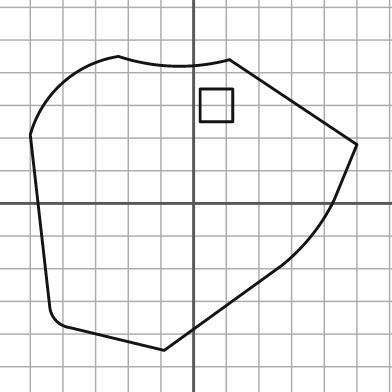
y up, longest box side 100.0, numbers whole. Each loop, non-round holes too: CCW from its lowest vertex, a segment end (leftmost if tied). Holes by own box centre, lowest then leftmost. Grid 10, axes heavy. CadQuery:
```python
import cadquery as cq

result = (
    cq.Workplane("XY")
    .moveTo(-9.0, -45.0)
    .lineTo(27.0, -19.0)
    .threePointArc((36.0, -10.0), (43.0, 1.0))
    .lineTo(50.0, 18.0)
    .lineTo(11.0, 44.0)
    .threePointArc((-6.0, 42.0), (-23.0, 45.0))
    .threePointArc((-40.0, 37.0), (-50.0, 21.0))
    .lineTo(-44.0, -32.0)
    .threePointArc((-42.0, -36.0), (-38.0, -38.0))
    .close()
    .moveTo(2.0, 25.0)
    .lineTo(12.0, 25.0)
    .lineTo(12.0, 35.0)
    .lineTo(2.0, 35.0)
    .close()
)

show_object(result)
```